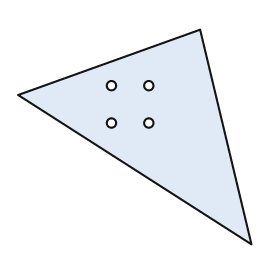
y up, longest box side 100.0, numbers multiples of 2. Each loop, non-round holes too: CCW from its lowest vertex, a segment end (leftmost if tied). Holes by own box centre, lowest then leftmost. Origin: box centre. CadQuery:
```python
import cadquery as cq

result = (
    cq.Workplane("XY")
    .moveTo(50.0, -46.0)
    .lineTo(28.0, 46.0)
    .lineTo(-50.0, 18.0)
    .close()
    .moveTo(-10.0, 6.0)
    .circle(2.0)
    .moveTo(6.0, 6.0)
    .circle(2.0)
    .moveTo(-10.0, 22.0)
    .circle(2.0)
    .moveTo(6.0, 22.0)
    .circle(2.0)
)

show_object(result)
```